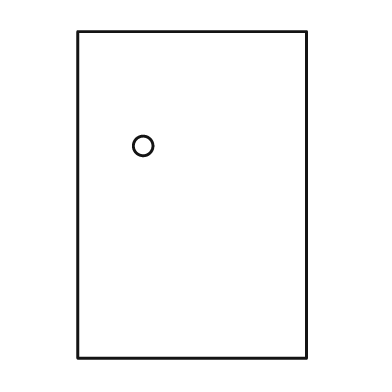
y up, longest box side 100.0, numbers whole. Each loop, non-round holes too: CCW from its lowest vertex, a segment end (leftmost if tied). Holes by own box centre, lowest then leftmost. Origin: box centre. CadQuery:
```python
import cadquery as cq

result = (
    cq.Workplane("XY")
    .moveTo(-35.0, -50.0)
    .lineTo(35.0, -50.0)
    .lineTo(35.0, 50.0)
    .lineTo(-35.0, 50.0)
    .close()
    .moveTo(-15.0, 15.0)
    .circle(3.0)
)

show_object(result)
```